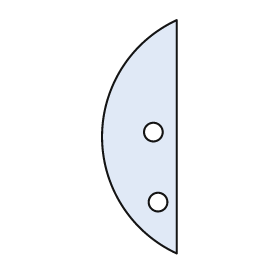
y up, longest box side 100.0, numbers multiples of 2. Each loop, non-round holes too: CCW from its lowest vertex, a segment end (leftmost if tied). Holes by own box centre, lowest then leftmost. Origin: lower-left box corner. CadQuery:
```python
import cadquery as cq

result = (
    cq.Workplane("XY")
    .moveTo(32.0, 0.0)
    .lineTo(32.0, 100.0)
    .threePointArc((0.0, 50.0), (32.0, 0.0))
    .close()
    .moveTo(24.0, 22.0)
    .circle(4.0)
    .moveTo(22.0, 52.0)
    .circle(4.0)
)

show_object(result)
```